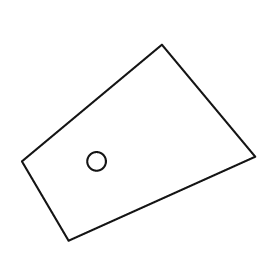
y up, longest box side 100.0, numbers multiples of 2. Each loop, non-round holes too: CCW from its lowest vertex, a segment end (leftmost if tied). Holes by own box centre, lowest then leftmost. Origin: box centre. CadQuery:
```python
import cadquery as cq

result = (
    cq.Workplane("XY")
    .moveTo(-30.0, -42.0)
    .lineTo(50.0, -6.0)
    .lineTo(10.0, 42.0)
    .lineTo(-50.0, -8.0)
    .close()
    .moveTo(-18.0, -8.0)
    .circle(4.0)
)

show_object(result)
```